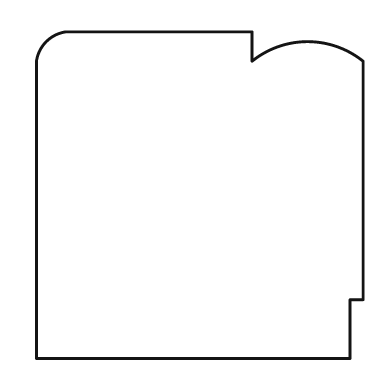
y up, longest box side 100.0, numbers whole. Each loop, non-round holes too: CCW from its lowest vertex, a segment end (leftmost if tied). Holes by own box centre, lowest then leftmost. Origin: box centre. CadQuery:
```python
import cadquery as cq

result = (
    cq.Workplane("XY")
    .moveTo(-50.0, -50.0)
    .lineTo(46.0, -50.0)
    .lineTo(46.0, -32.0)
    .lineTo(50.0, -32.0)
    .lineTo(50.0, 41.0)
    .threePointArc((33.0, 47.0), (16.0, 41.0))
    .lineTo(16.0, 50.0)
    .lineTo(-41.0, 50.0)
    .threePointArc((-47.0, 47.0), (-50.0, 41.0))
    .close()
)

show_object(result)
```